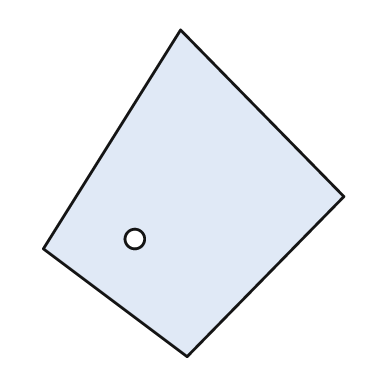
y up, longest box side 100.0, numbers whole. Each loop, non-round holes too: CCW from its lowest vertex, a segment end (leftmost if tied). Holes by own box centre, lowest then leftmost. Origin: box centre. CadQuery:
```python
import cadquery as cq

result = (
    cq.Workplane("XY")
    .moveTo(-2.0, -50.0)
    .lineTo(46.0, -1.0)
    .lineTo(-4.0, 50.0)
    .lineTo(-46.0, -17.0)
    .close()
    .moveTo(-18.0, -14.0)
    .circle(3.0)
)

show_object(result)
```